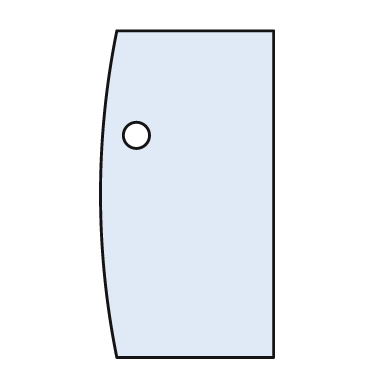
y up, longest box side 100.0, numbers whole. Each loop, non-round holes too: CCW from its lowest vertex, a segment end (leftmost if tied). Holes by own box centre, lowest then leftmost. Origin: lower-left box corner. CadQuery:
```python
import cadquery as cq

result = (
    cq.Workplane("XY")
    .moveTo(5.0, 0.0)
    .lineTo(53.0, 0.0)
    .lineTo(53.0, 100.0)
    .lineTo(5.0, 100.0)
    .threePointArc((0.0, 50.0), (5.0, 0.0))
    .close()
    .moveTo(11.0, 68.0)
    .circle(4.0)
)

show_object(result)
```